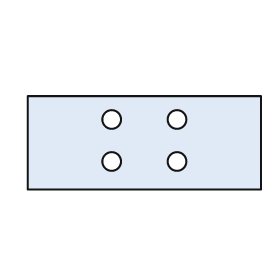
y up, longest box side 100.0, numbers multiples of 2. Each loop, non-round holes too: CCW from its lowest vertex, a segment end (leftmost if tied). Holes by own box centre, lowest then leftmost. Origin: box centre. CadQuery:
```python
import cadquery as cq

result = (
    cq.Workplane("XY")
    .moveTo(-50.0, -20.0)
    .lineTo(50.0, -20.0)
    .lineTo(50.0, 20.0)
    .lineTo(-50.0, 20.0)
    .close()
    .moveTo(-14.0, -8.0)
    .circle(4.0)
    .moveTo(14.0, -8.0)
    .circle(4.0)
    .moveTo(-14.0, 10.0)
    .circle(4.0)
    .moveTo(14.0, 10.0)
    .circle(4.0)
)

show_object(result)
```